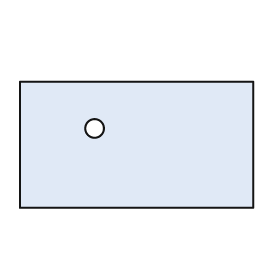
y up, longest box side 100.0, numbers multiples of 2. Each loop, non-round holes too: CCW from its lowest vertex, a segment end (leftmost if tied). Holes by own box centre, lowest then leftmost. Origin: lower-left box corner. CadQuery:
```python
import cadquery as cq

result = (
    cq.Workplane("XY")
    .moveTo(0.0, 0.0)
    .lineTo(100.0, 0.0)
    .lineTo(100.0, 54.0)
    .lineTo(0.0, 54.0)
    .close()
    .moveTo(32.0, 34.0)
    .circle(4.0)
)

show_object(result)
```